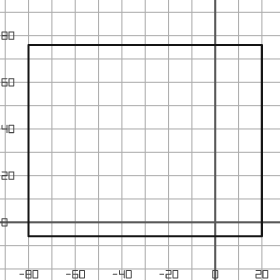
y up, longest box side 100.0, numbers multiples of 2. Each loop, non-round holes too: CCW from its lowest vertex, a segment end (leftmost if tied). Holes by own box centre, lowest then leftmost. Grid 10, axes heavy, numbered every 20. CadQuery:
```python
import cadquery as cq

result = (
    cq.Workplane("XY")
    .moveTo(-80.0, -6.0)
    .lineTo(20.0, -6.0)
    .lineTo(20.0, 76.0)
    .lineTo(-80.0, 76.0)
    .close()
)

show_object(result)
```